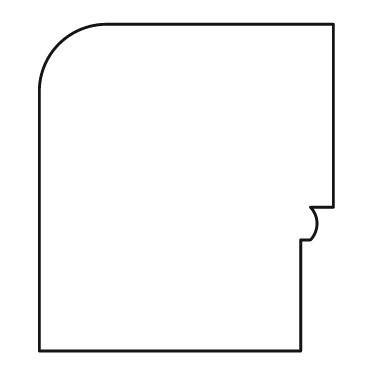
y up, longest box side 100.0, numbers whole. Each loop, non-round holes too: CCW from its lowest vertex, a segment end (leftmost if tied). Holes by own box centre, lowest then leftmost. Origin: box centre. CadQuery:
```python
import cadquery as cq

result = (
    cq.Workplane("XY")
    .moveTo(-45.0, -50.0)
    .lineTo(35.0, -50.0)
    .lineTo(35.0, -16.0)
    .lineTo(38.0, -16.0)
    .threePointArc((40.0, -11.0), (38.0, -6.0))
    .lineTo(45.0, -6.0)
    .lineTo(45.0, 50.0)
    .lineTo(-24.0, 50.0)
    .threePointArc((-39.0, 44.0), (-45.0, 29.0))
    .close()
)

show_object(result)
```